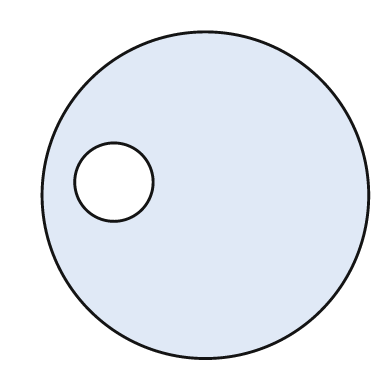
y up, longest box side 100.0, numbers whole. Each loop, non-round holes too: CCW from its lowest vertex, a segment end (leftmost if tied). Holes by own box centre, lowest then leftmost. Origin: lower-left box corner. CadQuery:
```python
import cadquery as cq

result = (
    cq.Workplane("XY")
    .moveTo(50.0, 50.0)
    .circle(50.0)
    .moveTo(22.0, 54.0)
    .circle(12.0)
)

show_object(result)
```